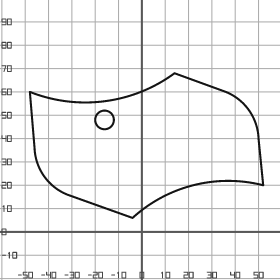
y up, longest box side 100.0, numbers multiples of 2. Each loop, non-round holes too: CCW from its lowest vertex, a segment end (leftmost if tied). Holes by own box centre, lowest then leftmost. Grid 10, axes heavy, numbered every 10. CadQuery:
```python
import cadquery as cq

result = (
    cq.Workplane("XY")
    .moveTo(-4.0, 6.0)
    .threePointArc((22.0, 20.0), (52.0, 20.0))
    .lineTo(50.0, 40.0)
    .threePointArc((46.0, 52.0), (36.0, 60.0))
    .lineTo(14.0, 68.0)
    .threePointArc((-16.0, 56.0), (-48.0, 60.0))
    .lineTo(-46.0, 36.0)
    .threePointArc((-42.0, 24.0), (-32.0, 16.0))
    .close()
    .moveTo(-16.0, 48.0)
    .circle(4.0)
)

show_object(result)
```